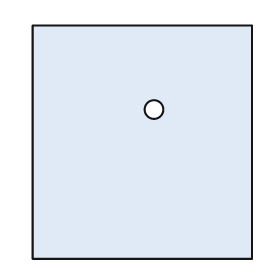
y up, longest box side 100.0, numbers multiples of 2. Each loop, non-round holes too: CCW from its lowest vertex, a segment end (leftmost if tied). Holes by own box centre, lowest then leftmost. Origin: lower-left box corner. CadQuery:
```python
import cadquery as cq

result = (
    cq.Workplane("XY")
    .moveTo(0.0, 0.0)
    .lineTo(94.0, 0.0)
    .lineTo(94.0, 100.0)
    .lineTo(0.0, 100.0)
    .close()
    .moveTo(52.0, 64.0)
    .circle(4.0)
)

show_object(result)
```